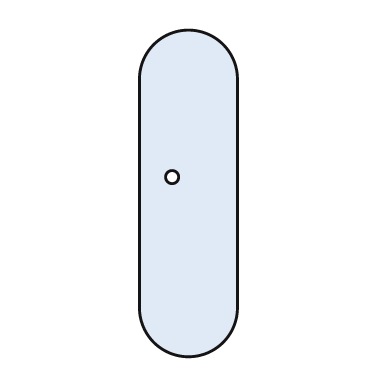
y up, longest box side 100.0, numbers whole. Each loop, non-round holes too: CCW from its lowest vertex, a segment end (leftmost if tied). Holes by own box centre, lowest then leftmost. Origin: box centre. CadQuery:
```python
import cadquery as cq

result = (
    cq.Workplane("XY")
    .moveTo(-15.0, -35.0)
    .threePointArc((0.0, -50.0), (15.0, -35.0))
    .lineTo(15.0, 35.0)
    .threePointArc((0.0, 50.0), (-15.0, 35.0))
    .close()
    .moveTo(-5.0, 5.0)
    .circle(2.0)
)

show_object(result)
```